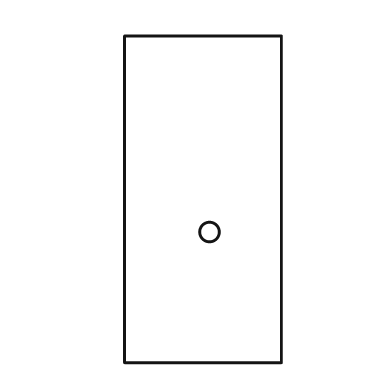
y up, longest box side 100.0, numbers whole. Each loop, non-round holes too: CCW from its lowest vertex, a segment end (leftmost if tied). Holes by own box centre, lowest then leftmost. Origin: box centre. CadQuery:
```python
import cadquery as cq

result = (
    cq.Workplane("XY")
    .moveTo(-24.0, -50.0)
    .lineTo(24.0, -50.0)
    .lineTo(24.0, 50.0)
    .lineTo(-24.0, 50.0)
    .close()
    .moveTo(2.0, -10.0)
    .circle(3.0)
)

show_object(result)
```